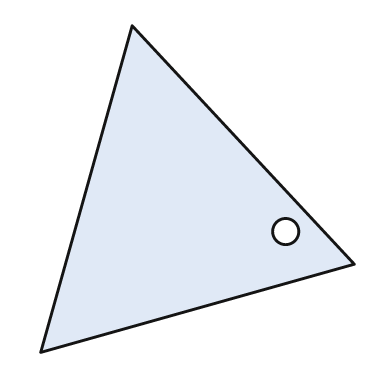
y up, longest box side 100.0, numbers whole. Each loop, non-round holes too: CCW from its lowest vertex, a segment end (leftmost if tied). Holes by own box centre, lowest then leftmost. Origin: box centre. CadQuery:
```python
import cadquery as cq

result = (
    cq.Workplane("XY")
    .moveTo(-48.0, -50.0)
    .lineTo(48.0, -23.0)
    .lineTo(-20.0, 50.0)
    .close()
    .moveTo(27.0, -13.0)
    .circle(4.0)
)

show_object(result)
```